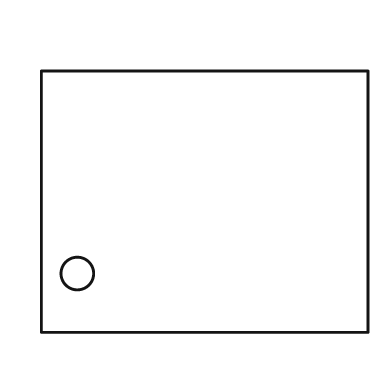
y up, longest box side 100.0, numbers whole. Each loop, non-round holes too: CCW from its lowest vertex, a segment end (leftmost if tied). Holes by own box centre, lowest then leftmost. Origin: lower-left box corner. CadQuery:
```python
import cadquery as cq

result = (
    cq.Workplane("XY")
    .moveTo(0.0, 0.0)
    .lineTo(100.0, 0.0)
    .lineTo(100.0, 80.0)
    .lineTo(0.0, 80.0)
    .close()
    .moveTo(11.0, 18.0)
    .circle(5.0)
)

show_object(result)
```